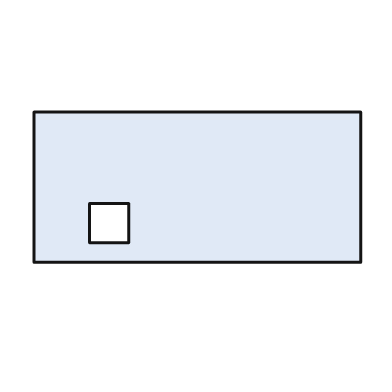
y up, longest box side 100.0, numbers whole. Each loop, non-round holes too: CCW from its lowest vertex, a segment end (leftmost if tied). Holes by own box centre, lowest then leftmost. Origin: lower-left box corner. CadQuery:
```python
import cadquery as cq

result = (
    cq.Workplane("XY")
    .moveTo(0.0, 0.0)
    .lineTo(100.0, 0.0)
    .lineTo(100.0, 46.0)
    .lineTo(0.0, 46.0)
    .close()
    .moveTo(17.0, 6.0)
    .lineTo(29.0, 6.0)
    .lineTo(29.0, 18.0)
    .lineTo(17.0, 18.0)
    .close()
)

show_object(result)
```